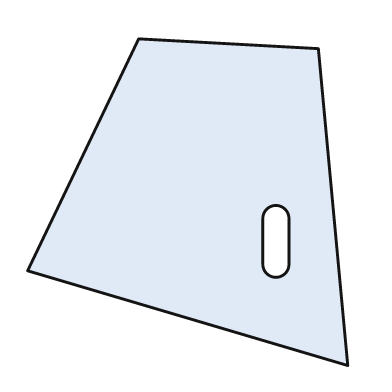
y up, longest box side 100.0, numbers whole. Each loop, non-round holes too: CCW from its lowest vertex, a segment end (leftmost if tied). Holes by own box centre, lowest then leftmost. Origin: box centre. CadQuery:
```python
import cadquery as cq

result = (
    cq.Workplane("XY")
    .moveTo(49.0, -50.0)
    .lineTo(40.0, 47.0)
    .lineTo(-15.0, 50.0)
    .lineTo(-49.0, -21.0)
    .close()
    .moveTo(23.0, -19.0)
    .threePointArc((27.0, -23.0), (31.0, -19.0))
    .lineTo(31.0, -5.0)
    .threePointArc((27.0, -1.0), (23.0, -5.0))
    .close()
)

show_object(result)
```